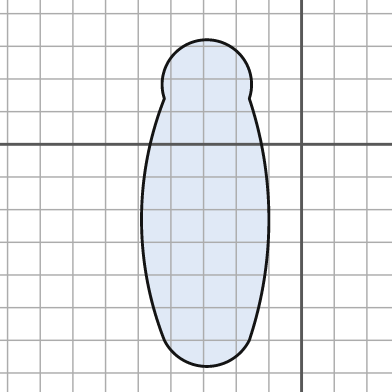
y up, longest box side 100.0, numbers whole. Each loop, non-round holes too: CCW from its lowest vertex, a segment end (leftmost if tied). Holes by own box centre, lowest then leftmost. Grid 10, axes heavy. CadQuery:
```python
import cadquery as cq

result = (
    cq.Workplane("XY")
    .moveTo(-42.0, -60.0)
    .threePointArc((-29.0, -68.0), (-16.0, -60.0))
    .threePointArc((-10.0, -23.0), (-16.0, 14.0))
    .threePointArc((-29.0, 32.0), (-42.0, 14.0))
    .threePointArc((-49.0, -23.0), (-42.0, -60.0))
    .close()
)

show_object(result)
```